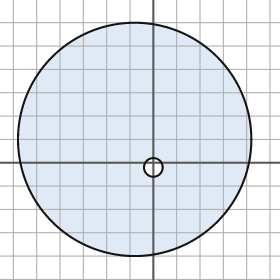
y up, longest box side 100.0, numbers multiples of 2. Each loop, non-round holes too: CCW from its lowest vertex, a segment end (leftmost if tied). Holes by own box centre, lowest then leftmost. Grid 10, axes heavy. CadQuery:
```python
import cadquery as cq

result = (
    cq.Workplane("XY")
    .moveTo(-8.0, 10.0)
    .circle(50.0)
    .moveTo(0.0, -2.0)
    .circle(4.0)
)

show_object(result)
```